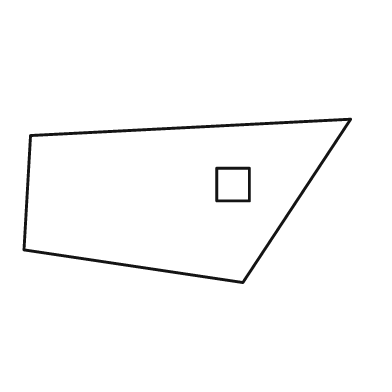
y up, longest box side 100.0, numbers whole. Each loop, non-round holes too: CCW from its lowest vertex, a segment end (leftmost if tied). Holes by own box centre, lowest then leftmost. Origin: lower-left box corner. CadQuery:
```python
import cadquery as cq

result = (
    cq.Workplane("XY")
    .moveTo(67.0, 0.0)
    .lineTo(100.0, 50.0)
    .lineTo(2.0, 45.0)
    .lineTo(0.0, 10.0)
    .close()
    .moveTo(59.0, 25.0)
    .lineTo(69.0, 25.0)
    .lineTo(69.0, 35.0)
    .lineTo(59.0, 35.0)
    .close()
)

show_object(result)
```